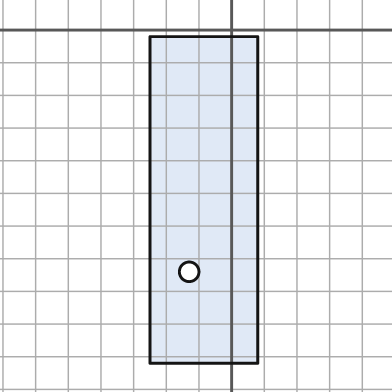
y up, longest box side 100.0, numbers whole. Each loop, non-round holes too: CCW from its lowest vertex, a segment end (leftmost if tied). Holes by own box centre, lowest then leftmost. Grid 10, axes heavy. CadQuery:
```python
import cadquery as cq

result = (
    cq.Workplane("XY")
    .moveTo(-25.0, -102.0)
    .lineTo(8.0, -102.0)
    .lineTo(8.0, -2.0)
    .lineTo(-25.0, -2.0)
    .close()
    .moveTo(-13.0, -74.0)
    .circle(3.0)
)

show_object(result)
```